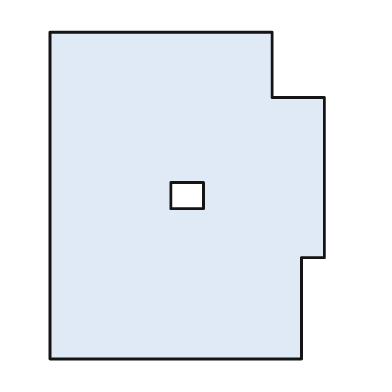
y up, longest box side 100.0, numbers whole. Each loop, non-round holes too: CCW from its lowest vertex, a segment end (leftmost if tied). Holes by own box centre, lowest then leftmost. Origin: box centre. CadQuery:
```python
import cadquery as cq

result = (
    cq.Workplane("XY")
    .moveTo(-42.0, -50.0)
    .lineTo(35.0, -50.0)
    .lineTo(35.0, -19.0)
    .lineTo(42.0, -19.0)
    .lineTo(42.0, 30.0)
    .lineTo(26.0, 30.0)
    .lineTo(26.0, 50.0)
    .lineTo(-42.0, 50.0)
    .close()
    .moveTo(-5.0, -4.0)
    .lineTo(5.0, -4.0)
    .lineTo(5.0, 4.0)
    .lineTo(-5.0, 4.0)
    .close()
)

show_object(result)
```